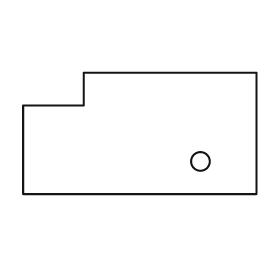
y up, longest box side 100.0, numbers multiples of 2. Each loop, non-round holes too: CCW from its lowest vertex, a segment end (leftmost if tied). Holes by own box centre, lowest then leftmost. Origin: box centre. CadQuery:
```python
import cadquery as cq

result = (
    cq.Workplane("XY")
    .moveTo(-50.0, -26.0)
    .lineTo(50.0, -26.0)
    .lineTo(50.0, 26.0)
    .lineTo(-24.0, 26.0)
    .lineTo(-24.0, 12.0)
    .lineTo(-50.0, 12.0)
    .close()
    .moveTo(26.0, -12.0)
    .circle(4.0)
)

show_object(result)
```